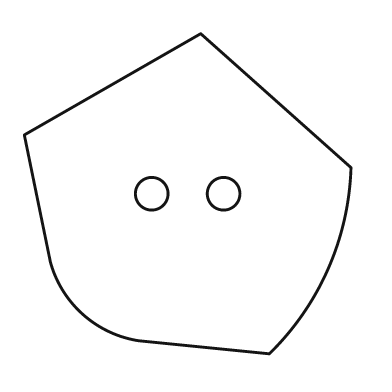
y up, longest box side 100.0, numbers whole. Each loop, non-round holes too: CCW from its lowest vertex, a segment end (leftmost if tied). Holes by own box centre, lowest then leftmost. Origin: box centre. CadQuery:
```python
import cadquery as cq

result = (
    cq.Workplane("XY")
    .moveTo(25.0, -49.0)
    .threePointArc((43.0, -23.0), (50.0, 8.0))
    .lineTo(4.0, 49.0)
    .lineTo(-50.0, 18.0)
    .lineTo(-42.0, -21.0)
    .threePointArc((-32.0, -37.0), (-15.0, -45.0))
    .close()
    .moveTo(-11.0, 0.0)
    .circle(5.0)
    .moveTo(11.0, 0.0)
    .circle(5.0)
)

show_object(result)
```